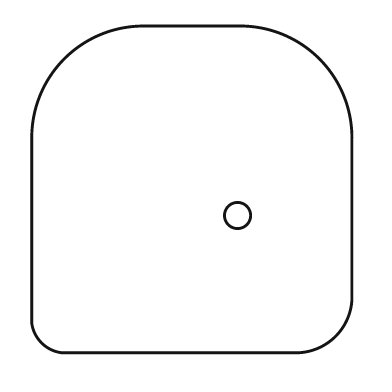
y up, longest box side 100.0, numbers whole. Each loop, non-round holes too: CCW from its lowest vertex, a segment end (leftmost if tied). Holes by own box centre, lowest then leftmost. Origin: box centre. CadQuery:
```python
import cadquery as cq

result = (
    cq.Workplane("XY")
    .moveTo(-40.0, -50.0)
    .lineTo(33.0, -50.0)
    .threePointArc((44.0, -45.0), (49.0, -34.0))
    .lineTo(49.0, 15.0)
    .threePointArc((39.0, 40.0), (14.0, 50.0))
    .lineTo(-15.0, 50.0)
    .threePointArc((-39.0, 40.0), (-49.0, 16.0))
    .lineTo(-49.0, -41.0)
    .threePointArc((-46.0, -47.0), (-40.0, -50.0))
    .close()
    .moveTo(14.0, -8.0)
    .circle(4.0)
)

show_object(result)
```